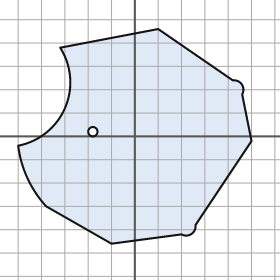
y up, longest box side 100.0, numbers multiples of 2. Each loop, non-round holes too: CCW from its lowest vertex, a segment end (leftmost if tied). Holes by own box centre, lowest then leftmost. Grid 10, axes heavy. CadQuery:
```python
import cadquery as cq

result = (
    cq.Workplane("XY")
    .moveTo(-10.0, -46.0)
    .lineTo(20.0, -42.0)
    .threePointArc((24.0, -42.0), (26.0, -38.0))
    .lineTo(50.0, -2.0)
    .lineTo(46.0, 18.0)
    .threePointArc((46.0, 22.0), (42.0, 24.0))
    .lineTo(10.0, 46.0)
    .lineTo(-32.0, 38.0)
    .threePointArc((-30.0, 12.0), (-50.0, -4.0))
    .threePointArc((-46.0, -18.0), (-38.0, -30.0))
    .close()
    .moveTo(-18.0, 2.0)
    .circle(2.0)
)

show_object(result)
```